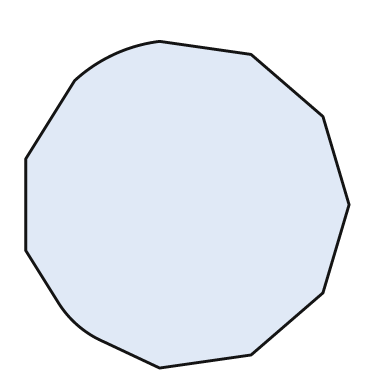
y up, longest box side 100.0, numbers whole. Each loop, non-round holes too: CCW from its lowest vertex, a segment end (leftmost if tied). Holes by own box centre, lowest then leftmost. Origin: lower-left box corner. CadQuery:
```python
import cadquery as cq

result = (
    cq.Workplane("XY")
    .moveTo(41.0, 0.0)
    .lineTo(69.0, 4.0)
    .lineTo(91.0, 23.0)
    .lineTo(99.0, 50.0)
    .lineTo(91.0, 77.0)
    .lineTo(69.0, 96.0)
    .lineTo(41.0, 100.0)
    .threePointArc((27.0, 96.0), (15.0, 88.0))
    .lineTo(0.0, 64.0)
    .lineTo(0.0, 36.0)
    .lineTo(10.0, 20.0)
    .threePointArc((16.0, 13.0), (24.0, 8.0))
    .close()
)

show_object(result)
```